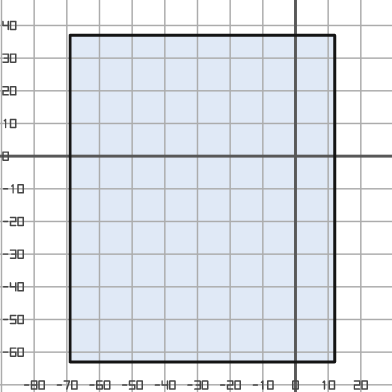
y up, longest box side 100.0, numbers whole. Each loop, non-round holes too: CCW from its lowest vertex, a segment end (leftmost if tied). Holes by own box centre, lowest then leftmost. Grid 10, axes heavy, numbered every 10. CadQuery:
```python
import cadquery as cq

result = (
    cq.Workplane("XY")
    .moveTo(-69.0, -63.0)
    .lineTo(12.0, -63.0)
    .lineTo(12.0, 37.0)
    .lineTo(-69.0, 37.0)
    .close()
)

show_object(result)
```